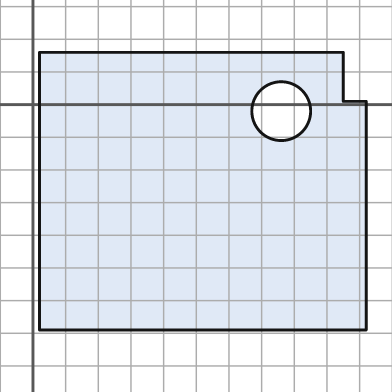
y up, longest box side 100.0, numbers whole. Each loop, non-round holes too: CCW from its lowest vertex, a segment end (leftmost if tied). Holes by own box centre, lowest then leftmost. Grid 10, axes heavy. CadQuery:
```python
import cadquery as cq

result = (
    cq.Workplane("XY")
    .moveTo(2.0, -69.0)
    .lineTo(102.0, -69.0)
    .lineTo(102.0, 1.0)
    .lineTo(95.0, 1.0)
    .lineTo(95.0, 16.0)
    .lineTo(2.0, 16.0)
    .close()
    .moveTo(76.0, -2.0)
    .circle(9.0)
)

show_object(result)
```